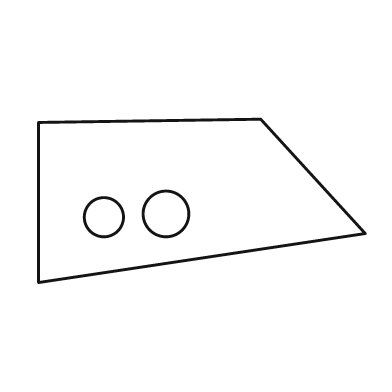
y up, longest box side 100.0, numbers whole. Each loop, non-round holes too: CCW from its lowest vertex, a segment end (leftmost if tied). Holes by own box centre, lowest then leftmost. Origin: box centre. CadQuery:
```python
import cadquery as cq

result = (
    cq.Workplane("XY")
    .moveTo(-50.0, -25.0)
    .lineTo(50.0, -10.0)
    .lineTo(18.0, 25.0)
    .lineTo(-50.0, 24.0)
    .close()
    .moveTo(-30.0, -5.0)
    .circle(6.0)
    .moveTo(-11.0, -4.0)
    .circle(7.0)
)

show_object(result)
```